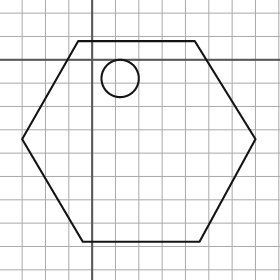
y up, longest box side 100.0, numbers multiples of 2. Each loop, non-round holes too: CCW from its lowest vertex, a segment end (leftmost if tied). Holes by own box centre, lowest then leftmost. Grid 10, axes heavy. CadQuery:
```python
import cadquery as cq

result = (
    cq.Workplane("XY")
    .moveTo(-4.0, -78.0)
    .lineTo(46.0, -78.0)
    .lineTo(70.0, -34.0)
    .lineTo(44.0, 8.0)
    .lineTo(-6.0, 8.0)
    .lineTo(-30.0, -34.0)
    .close()
    .moveTo(12.0, -8.0)
    .circle(8.0)
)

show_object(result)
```